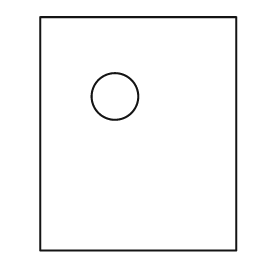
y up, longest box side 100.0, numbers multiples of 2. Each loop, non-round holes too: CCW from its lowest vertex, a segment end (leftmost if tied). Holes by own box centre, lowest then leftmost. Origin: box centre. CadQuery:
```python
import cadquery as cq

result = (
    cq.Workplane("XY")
    .moveTo(-42.0, -50.0)
    .lineTo(42.0, -50.0)
    .lineTo(42.0, 50.0)
    .lineTo(-42.0, 50.0)
    .close()
    .moveTo(-10.0, 16.0)
    .circle(10.0)
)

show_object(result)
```